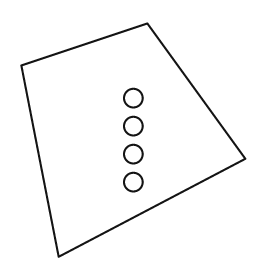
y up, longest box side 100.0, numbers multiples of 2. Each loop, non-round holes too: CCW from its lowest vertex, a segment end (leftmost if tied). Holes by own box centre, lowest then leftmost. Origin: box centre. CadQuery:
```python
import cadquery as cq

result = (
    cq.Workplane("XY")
    .moveTo(-32.0, -50.0)
    .lineTo(48.0, -8.0)
    .lineTo(6.0, 50.0)
    .lineTo(-48.0, 32.0)
    .close()
    .moveTo(0.0, -18.0)
    .circle(4.0)
    .moveTo(0.0, -6.0)
    .circle(4.0)
    .moveTo(0.0, 6.0)
    .circle(4.0)
    .moveTo(0.0, 18.0)
    .circle(4.0)
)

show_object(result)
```